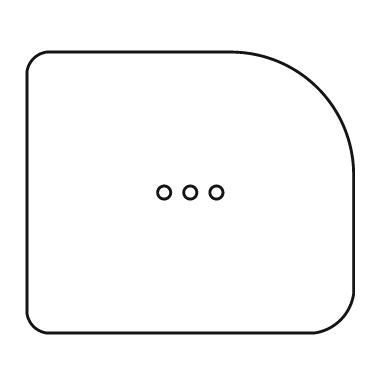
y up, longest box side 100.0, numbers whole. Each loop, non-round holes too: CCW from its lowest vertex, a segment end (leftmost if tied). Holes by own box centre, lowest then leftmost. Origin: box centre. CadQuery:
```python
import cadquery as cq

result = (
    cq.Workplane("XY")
    .moveTo(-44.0, -43.0)
    .lineTo(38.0, -43.0)
    .threePointArc((46.0, -39.0), (50.0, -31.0))
    .lineTo(50.0, 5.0)
    .threePointArc((39.0, 32.0), (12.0, 43.0))
    .lineTo(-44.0, 43.0)
    .threePointArc((-48.0, 41.0), (-50.0, 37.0))
    .lineTo(-50.0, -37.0)
    .threePointArc((-48.0, -41.0), (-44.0, -43.0))
    .close()
    .moveTo(-8.0, 0.0)
    .circle(2.0)
    .moveTo(0.0, 0.0)
    .circle(2.0)
    .moveTo(8.0, 0.0)
    .circle(2.0)
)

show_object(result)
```